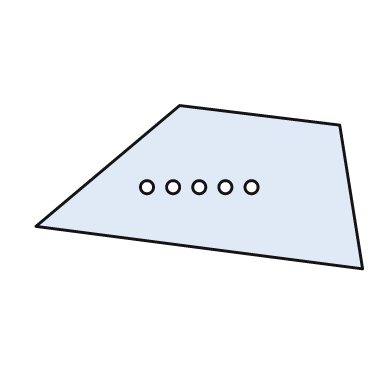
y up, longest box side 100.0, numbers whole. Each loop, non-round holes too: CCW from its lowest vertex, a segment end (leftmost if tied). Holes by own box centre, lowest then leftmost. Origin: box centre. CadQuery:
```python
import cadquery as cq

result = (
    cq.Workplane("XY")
    .moveTo(50.0, -25.0)
    .lineTo(43.0, 19.0)
    .lineTo(-6.0, 25.0)
    .lineTo(-50.0, -12.0)
    .close()
    .moveTo(-16.0, 0.0)
    .circle(2.0)
    .moveTo(-8.0, 0.0)
    .circle(2.0)
    .moveTo(0.0, 0.0)
    .circle(2.0)
    .moveTo(8.0, 0.0)
    .circle(2.0)
    .moveTo(16.0, 0.0)
    .circle(2.0)
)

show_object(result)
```